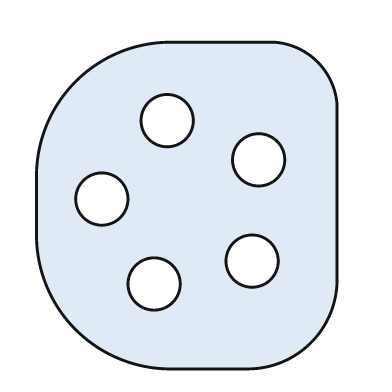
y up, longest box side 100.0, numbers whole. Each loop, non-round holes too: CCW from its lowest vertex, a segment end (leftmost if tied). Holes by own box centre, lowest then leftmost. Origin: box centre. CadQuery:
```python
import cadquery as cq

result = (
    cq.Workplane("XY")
    .moveTo(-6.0, -50.0)
    .lineTo(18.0, -50.0)
    .threePointArc((38.0, -42.0), (46.0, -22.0))
    .lineTo(46.0, 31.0)
    .threePointArc((40.0, 44.0), (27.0, 50.0))
    .lineTo(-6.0, 50.0)
    .threePointArc((-34.0, 38.0), (-46.0, 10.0))
    .lineTo(-46.0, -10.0)
    .threePointArc((-34.0, -38.0), (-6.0, -50.0))
    .close()
    .moveTo(-10.0, -24.0)
    .circle(8.0)
    .moveTo(20.0, -17.0)
    .circle(8.0)
    .moveTo(-26.0, 2.0)
    .circle(8.0)
    .moveTo(22.0, 14.0)
    .circle(8.0)
    .moveTo(-6.0, 26.0)
    .circle(8.0)
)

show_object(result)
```